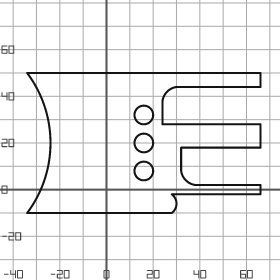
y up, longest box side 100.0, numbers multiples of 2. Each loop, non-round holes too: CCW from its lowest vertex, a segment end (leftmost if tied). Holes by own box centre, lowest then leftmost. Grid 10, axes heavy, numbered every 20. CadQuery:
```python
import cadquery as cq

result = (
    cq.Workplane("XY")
    .moveTo(-34.0, -10.0)
    .lineTo(28.0, -10.0)
    .threePointArc((30.0, -6.0), (28.0, -2.0))
    .lineTo(66.0, -2.0)
    .lineTo(66.0, 2.0)
    .lineTo(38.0, 2.0)
    .threePointArc((34.0, 4.0), (32.0, 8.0))
    .lineTo(32.0, 18.0)
    .lineTo(66.0, 18.0)
    .lineTo(66.0, 28.0)
    .lineTo(24.0, 28.0)
    .lineTo(24.0, 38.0)
    .threePointArc((26.0, 42.0), (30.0, 44.0))
    .lineTo(66.0, 44.0)
    .lineTo(66.0, 50.0)
    .lineTo(-34.0, 50.0)
    .threePointArc((-24.0, 20.0), (-34.0, -10.0))
    .close()
    .moveTo(16.0, 8.0)
    .circle(4.0)
    .moveTo(16.0, 20.0)
    .circle(4.0)
    .moveTo(16.0, 32.0)
    .circle(4.0)
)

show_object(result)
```